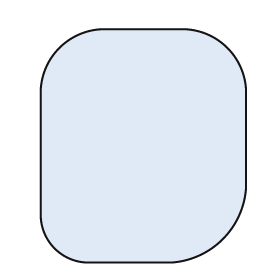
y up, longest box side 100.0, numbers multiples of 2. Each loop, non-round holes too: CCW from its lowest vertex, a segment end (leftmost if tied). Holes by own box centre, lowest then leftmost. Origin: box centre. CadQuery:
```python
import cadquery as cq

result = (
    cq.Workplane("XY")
    .moveTo(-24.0, -50.0)
    .lineTo(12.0, -50.0)
    .threePointArc((34.0, -40.0), (44.0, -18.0))
    .lineTo(44.0, 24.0)
    .threePointArc((36.0, 42.0), (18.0, 50.0))
    .lineTo(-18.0, 50.0)
    .threePointArc((-36.0, 42.0), (-44.0, 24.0))
    .lineTo(-44.0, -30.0)
    .threePointArc((-38.0, -44.0), (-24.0, -50.0))
    .close()
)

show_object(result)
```